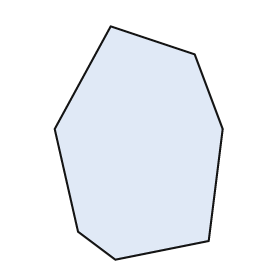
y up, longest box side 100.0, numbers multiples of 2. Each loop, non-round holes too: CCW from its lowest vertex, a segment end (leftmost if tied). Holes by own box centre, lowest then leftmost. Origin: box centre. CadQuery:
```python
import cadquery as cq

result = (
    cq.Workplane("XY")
    .moveTo(-10.0, -50.0)
    .lineTo(30.0, -42.0)
    .lineTo(36.0, 6.0)
    .lineTo(24.0, 38.0)
    .lineTo(-12.0, 50.0)
    .lineTo(-36.0, 6.0)
    .lineTo(-26.0, -38.0)
    .close()
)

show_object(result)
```